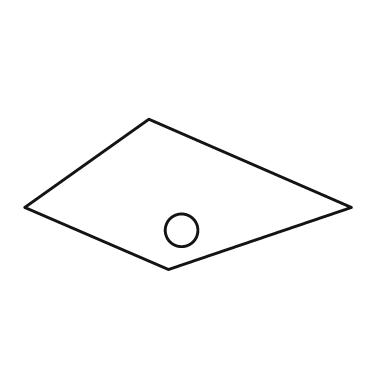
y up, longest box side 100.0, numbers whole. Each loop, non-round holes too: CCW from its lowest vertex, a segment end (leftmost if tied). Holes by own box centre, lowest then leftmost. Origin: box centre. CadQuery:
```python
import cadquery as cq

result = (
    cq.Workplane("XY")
    .moveTo(-6.0, -23.0)
    .lineTo(50.0, -4.0)
    .lineTo(-12.0, 23.0)
    .lineTo(-50.0, -4.0)
    .close()
    .moveTo(-2.0, -11.0)
    .circle(5.0)
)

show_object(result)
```